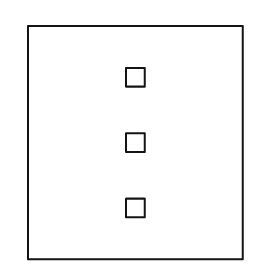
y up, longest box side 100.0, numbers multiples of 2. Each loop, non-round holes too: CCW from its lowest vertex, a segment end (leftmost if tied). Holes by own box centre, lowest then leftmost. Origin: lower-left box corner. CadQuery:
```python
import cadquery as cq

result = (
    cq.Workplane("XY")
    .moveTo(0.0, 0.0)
    .lineTo(92.0, 0.0)
    .lineTo(92.0, 100.0)
    .lineTo(0.0, 100.0)
    .close()
    .moveTo(42.0, 18.0)
    .lineTo(50.0, 18.0)
    .lineTo(50.0, 26.0)
    .lineTo(42.0, 26.0)
    .close()
    .moveTo(42.0, 46.0)
    .lineTo(50.0, 46.0)
    .lineTo(50.0, 54.0)
    .lineTo(42.0, 54.0)
    .close()
    .moveTo(42.0, 74.0)
    .lineTo(50.0, 74.0)
    .lineTo(50.0, 82.0)
    .lineTo(42.0, 82.0)
    .close()
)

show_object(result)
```